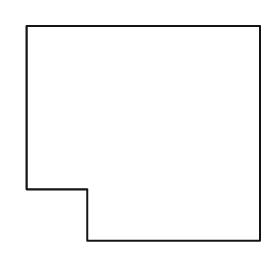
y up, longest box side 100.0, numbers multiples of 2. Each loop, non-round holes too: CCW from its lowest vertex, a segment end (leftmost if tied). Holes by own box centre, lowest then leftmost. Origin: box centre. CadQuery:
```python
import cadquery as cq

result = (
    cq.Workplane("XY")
    .moveTo(-24.0, -46.0)
    .lineTo(50.0, -46.0)
    .lineTo(50.0, 46.0)
    .lineTo(-50.0, 46.0)
    .lineTo(-50.0, -24.0)
    .lineTo(-24.0, -24.0)
    .close()
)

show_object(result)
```